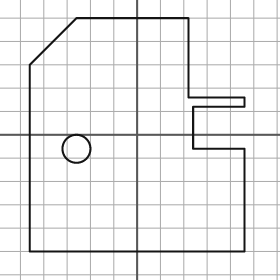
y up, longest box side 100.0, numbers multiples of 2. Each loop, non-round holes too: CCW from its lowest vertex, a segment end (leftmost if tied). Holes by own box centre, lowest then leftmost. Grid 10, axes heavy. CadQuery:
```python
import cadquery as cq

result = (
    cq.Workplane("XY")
    .moveTo(-46.0, -50.0)
    .lineTo(46.0, -50.0)
    .lineTo(46.0, -6.0)
    .lineTo(24.0, -6.0)
    .lineTo(24.0, 12.0)
    .lineTo(46.0, 12.0)
    .lineTo(46.0, 16.0)
    .lineTo(22.0, 16.0)
    .lineTo(22.0, 50.0)
    .lineTo(-26.0, 50.0)
    .lineTo(-46.0, 30.0)
    .close()
    .moveTo(-26.0, -6.0)
    .circle(6.0)
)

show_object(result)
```